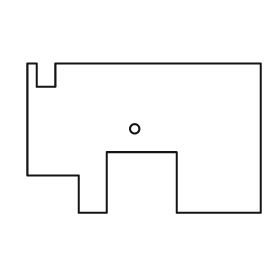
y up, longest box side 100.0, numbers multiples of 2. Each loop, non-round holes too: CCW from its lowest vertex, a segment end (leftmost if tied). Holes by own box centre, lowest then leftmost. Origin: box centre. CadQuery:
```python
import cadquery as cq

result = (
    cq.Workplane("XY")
    .moveTo(-28.0, -32.0)
    .lineTo(-16.0, -32.0)
    .lineTo(-16.0, -6.0)
    .lineTo(14.0, -6.0)
    .lineTo(14.0, -32.0)
    .lineTo(50.0, -32.0)
    .lineTo(50.0, 32.0)
    .lineTo(-38.0, 32.0)
    .lineTo(-38.0, 22.0)
    .lineTo(-46.0, 22.0)
    .lineTo(-46.0, 32.0)
    .lineTo(-50.0, 32.0)
    .lineTo(-50.0, -16.0)
    .lineTo(-28.0, -16.0)
    .close()
    .moveTo(-4.0, 4.0)
    .circle(2.0)
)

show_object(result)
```